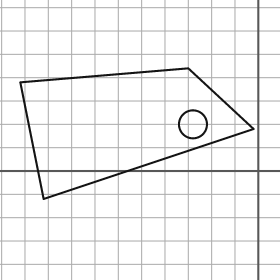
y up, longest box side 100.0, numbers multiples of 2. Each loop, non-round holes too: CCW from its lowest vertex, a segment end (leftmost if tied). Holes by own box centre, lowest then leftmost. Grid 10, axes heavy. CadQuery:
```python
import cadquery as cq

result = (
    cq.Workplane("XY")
    .moveTo(-92.0, -12.0)
    .lineTo(-2.0, 18.0)
    .lineTo(-30.0, 44.0)
    .lineTo(-102.0, 38.0)
    .close()
    .moveTo(-28.0, 20.0)
    .circle(6.0)
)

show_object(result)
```